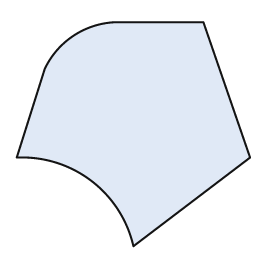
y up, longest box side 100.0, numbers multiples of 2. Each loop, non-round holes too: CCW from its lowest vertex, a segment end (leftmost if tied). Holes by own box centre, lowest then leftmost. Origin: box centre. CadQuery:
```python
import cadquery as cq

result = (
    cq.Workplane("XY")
    .moveTo(0.0, -48.0)
    .lineTo(50.0, -10.0)
    .lineTo(30.0, 48.0)
    .lineTo(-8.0, 48.0)
    .threePointArc((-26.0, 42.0), (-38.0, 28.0))
    .lineTo(-50.0, -10.0)
    .threePointArc((-18.0, -20.0), (0.0, -48.0))
    .close()
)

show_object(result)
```